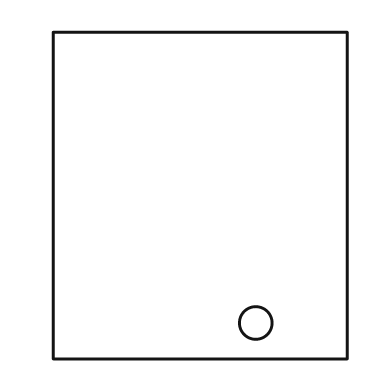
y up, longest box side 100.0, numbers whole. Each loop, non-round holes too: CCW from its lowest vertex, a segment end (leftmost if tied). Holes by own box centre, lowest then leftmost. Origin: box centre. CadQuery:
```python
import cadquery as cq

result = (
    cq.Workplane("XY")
    .moveTo(-45.0, -50.0)
    .lineTo(45.0, -50.0)
    .lineTo(45.0, 50.0)
    .lineTo(-45.0, 50.0)
    .close()
    .moveTo(17.0, -39.0)
    .circle(5.0)
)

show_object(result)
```